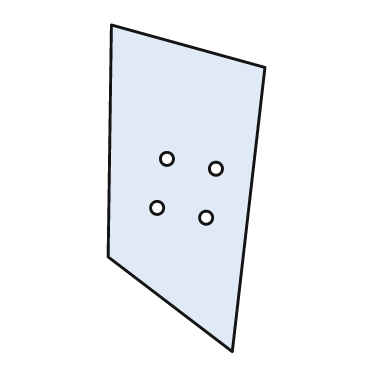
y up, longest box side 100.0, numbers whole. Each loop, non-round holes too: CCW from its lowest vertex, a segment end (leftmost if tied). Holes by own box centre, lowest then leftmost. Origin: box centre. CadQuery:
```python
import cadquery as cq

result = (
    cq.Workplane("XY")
    .moveTo(14.0, -50.0)
    .lineTo(24.0, 37.0)
    .lineTo(-23.0, 50.0)
    .lineTo(-24.0, -21.0)
    .close()
    .moveTo(6.0, -9.0)
    .circle(2.0)
    .moveTo(-9.0, -6.0)
    .circle(2.0)
    .moveTo(9.0, 6.0)
    .circle(2.0)
    .moveTo(-6.0, 9.0)
    .circle(2.0)
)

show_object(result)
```